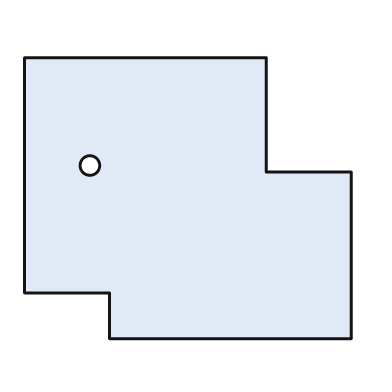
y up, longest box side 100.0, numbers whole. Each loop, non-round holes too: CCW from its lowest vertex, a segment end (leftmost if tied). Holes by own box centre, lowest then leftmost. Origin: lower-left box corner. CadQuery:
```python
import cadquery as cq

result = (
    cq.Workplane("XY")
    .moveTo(26.0, 0.0)
    .lineTo(100.0, 0.0)
    .lineTo(100.0, 51.0)
    .lineTo(74.0, 51.0)
    .lineTo(74.0, 86.0)
    .lineTo(0.0, 86.0)
    .lineTo(0.0, 14.0)
    .lineTo(26.0, 14.0)
    .close()
    .moveTo(20.0, 53.0)
    .circle(3.0)
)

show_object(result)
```